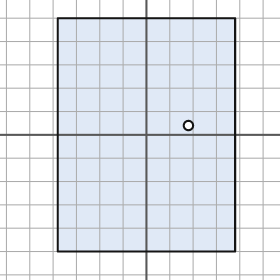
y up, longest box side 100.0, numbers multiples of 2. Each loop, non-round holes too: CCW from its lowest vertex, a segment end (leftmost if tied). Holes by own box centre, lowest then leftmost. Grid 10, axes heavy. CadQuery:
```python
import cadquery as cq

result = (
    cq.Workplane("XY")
    .moveTo(-38.0, -50.0)
    .lineTo(38.0, -50.0)
    .lineTo(38.0, 50.0)
    .lineTo(-38.0, 50.0)
    .close()
    .moveTo(18.0, 4.0)
    .circle(2.0)
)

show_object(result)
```